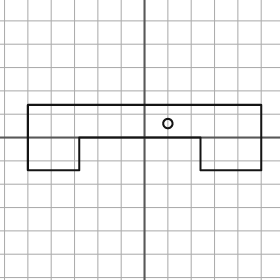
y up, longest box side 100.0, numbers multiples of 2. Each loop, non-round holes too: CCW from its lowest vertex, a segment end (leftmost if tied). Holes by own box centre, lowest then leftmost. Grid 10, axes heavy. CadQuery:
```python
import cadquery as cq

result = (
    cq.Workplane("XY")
    .moveTo(-50.0, -14.0)
    .lineTo(-28.0, -14.0)
    .lineTo(-28.0, 0.0)
    .lineTo(24.0, 0.0)
    .lineTo(24.0, -14.0)
    .lineTo(50.0, -14.0)
    .lineTo(50.0, 14.0)
    .lineTo(-50.0, 14.0)
    .close()
    .moveTo(10.0, 6.0)
    .circle(2.0)
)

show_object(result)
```